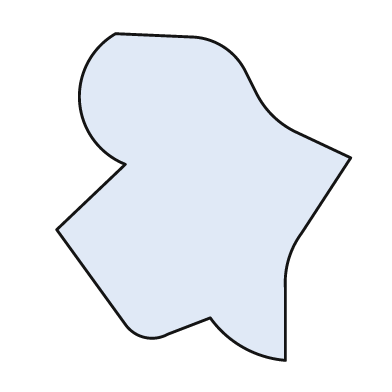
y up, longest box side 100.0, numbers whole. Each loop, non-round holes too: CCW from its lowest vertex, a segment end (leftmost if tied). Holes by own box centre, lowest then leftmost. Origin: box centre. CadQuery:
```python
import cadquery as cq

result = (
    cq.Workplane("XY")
    .moveTo(25.0, -50.0)
    .lineTo(25.0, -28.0)
    .threePointArc((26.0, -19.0), (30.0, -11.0))
    .lineTo(45.0, 12.0)
    .lineTo(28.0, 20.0)
    .threePointArc((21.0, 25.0), (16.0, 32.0))
    .lineTo(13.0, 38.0)
    .threePointArc((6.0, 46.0), (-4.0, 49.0))
    .lineTo(-27.0, 50.0)
    .threePointArc((-38.0, 29.0), (-24.0, 10.0))
    .lineTo(-45.0, -10.0)
    .lineTo(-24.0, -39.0)
    .threePointArc((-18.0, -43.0), (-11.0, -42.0))
    .lineTo(2.0, -37.0)
    .threePointArc((12.0, -46.0), (25.0, -50.0))
    .close()
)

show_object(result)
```